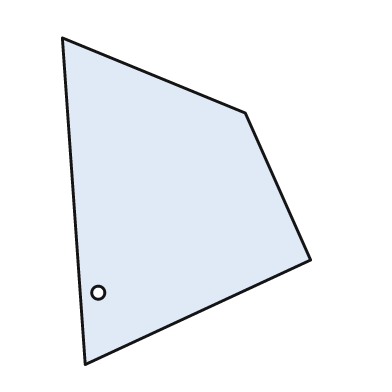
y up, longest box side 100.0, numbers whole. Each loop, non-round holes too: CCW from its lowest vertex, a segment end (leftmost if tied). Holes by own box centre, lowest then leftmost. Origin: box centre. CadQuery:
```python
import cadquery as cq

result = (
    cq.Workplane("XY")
    .moveTo(-31.0, -50.0)
    .lineTo(38.0, -18.0)
    .lineTo(18.0, 27.0)
    .lineTo(-38.0, 50.0)
    .close()
    .moveTo(-27.0, -28.0)
    .circle(2.0)
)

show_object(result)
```